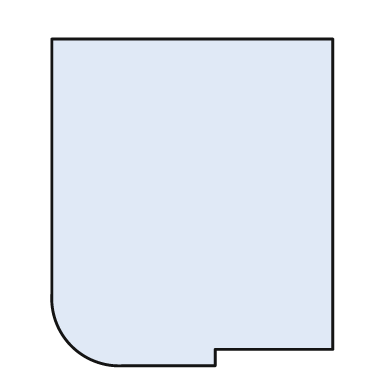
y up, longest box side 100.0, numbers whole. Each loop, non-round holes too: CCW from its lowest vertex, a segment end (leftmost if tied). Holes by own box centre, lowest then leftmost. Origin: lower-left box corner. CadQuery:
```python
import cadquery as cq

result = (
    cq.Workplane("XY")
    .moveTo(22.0, 0.0)
    .lineTo(50.0, 0.0)
    .lineTo(50.0, 5.0)
    .lineTo(86.0, 5.0)
    .lineTo(86.0, 100.0)
    .lineTo(0.0, 100.0)
    .lineTo(0.0, 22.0)
    .threePointArc((6.0, 6.0), (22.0, 0.0))
    .close()
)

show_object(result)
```